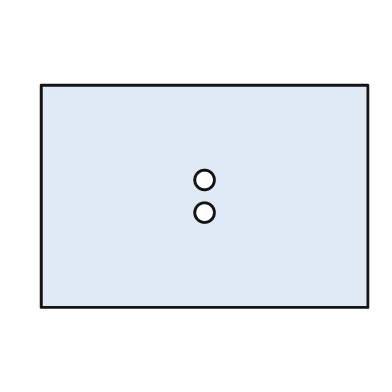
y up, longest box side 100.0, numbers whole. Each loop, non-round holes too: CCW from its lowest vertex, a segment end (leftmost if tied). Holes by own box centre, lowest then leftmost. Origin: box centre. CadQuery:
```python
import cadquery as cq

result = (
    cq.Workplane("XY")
    .moveTo(-50.0, -34.0)
    .lineTo(50.0, -34.0)
    .lineTo(50.0, 34.0)
    .lineTo(-50.0, 34.0)
    .close()
    .moveTo(0.0, -5.0)
    .circle(3.0)
    .moveTo(0.0, 5.0)
    .circle(3.0)
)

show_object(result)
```